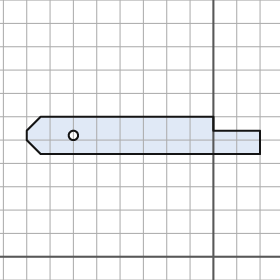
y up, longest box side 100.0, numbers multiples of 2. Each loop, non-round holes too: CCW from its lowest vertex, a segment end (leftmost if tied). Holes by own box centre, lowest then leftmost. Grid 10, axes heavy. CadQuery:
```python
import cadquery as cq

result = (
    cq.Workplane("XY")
    .moveTo(-74.0, 44.0)
    .lineTo(20.0, 44.0)
    .lineTo(20.0, 54.0)
    .lineTo(0.0, 54.0)
    .lineTo(0.0, 60.0)
    .lineTo(-74.0, 60.0)
    .lineTo(-80.0, 54.0)
    .lineTo(-80.0, 50.0)
    .close()
    .moveTo(-60.0, 52.0)
    .circle(2.0)
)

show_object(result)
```